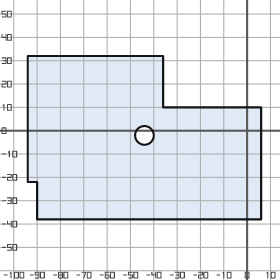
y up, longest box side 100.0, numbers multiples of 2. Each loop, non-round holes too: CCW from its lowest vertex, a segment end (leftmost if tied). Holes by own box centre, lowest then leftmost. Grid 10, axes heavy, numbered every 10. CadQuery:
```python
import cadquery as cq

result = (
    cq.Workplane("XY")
    .moveTo(-90.0, -38.0)
    .lineTo(6.0, -38.0)
    .lineTo(6.0, 10.0)
    .lineTo(-36.0, 10.0)
    .lineTo(-36.0, 32.0)
    .lineTo(-94.0, 32.0)
    .lineTo(-94.0, -22.0)
    .lineTo(-90.0, -22.0)
    .close()
    .moveTo(-44.0, -2.0)
    .circle(4.0)
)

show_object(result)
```